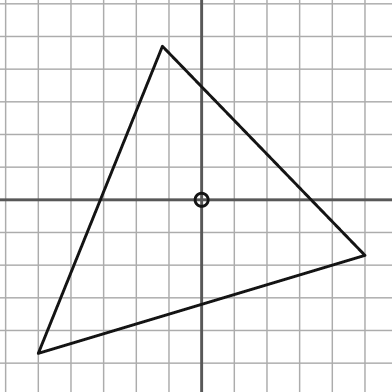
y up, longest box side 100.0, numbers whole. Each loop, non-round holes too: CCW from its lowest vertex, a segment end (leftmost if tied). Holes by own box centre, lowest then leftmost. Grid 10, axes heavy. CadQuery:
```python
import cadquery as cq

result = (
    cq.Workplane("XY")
    .moveTo(-50.0, -47.0)
    .lineTo(50.0, -17.0)
    .lineTo(-12.0, 47.0)
    .close()
    .moveTo(0.0, 0.0)
    .circle(2.0)
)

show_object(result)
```